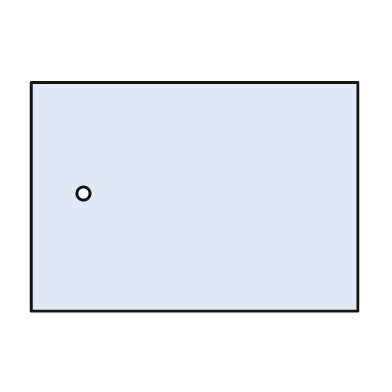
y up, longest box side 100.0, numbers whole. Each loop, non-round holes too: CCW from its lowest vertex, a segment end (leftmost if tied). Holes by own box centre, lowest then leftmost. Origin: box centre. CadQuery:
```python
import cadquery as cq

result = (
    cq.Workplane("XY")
    .moveTo(-50.0, -35.0)
    .lineTo(50.0, -35.0)
    .lineTo(50.0, 35.0)
    .lineTo(-50.0, 35.0)
    .close()
    .moveTo(-34.0, 1.0)
    .circle(2.0)
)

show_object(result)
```